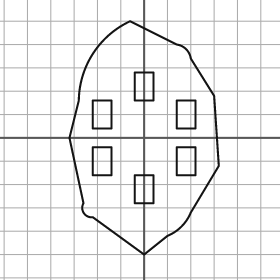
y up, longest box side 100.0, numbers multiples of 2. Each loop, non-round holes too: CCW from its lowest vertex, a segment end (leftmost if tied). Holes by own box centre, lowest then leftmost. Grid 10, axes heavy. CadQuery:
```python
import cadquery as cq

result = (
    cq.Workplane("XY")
    .moveTo(0.0, -50.0)
    .lineTo(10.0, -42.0)
    .threePointArc((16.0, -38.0), (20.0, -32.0))
    .lineTo(32.0, -12.0)
    .lineTo(30.0, 18.0)
    .lineTo(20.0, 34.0)
    .threePointArc((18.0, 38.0), (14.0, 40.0))
    .lineTo(-6.0, 50.0)
    .threePointArc((-22.0, 36.0), (-28.0, 16.0))
    .lineTo(-32.0, 0.0)
    .lineTo(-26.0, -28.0)
    .threePointArc((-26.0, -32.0), (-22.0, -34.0))
    .close()
    .moveTo(-4.0, -28.0)
    .lineTo(4.0, -28.0)
    .lineTo(4.0, -16.0)
    .lineTo(-4.0, -16.0)
    .close()
    .moveTo(-22.0, -16.0)
    .lineTo(-14.0, -16.0)
    .lineTo(-14.0, -4.0)
    .lineTo(-22.0, -4.0)
    .close()
    .moveTo(14.0, -16.0)
    .lineTo(22.0, -16.0)
    .lineTo(22.0, -4.0)
    .lineTo(14.0, -4.0)
    .close()
    .moveTo(-22.0, 4.0)
    .lineTo(-14.0, 4.0)
    .lineTo(-14.0, 16.0)
    .lineTo(-22.0, 16.0)
    .close()
    .moveTo(14.0, 4.0)
    .lineTo(22.0, 4.0)
    .lineTo(22.0, 16.0)
    .lineTo(14.0, 16.0)
    .close()
    .moveTo(-4.0, 16.0)
    .lineTo(4.0, 16.0)
    .lineTo(4.0, 28.0)
    .lineTo(-4.0, 28.0)
    .close()
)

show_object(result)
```